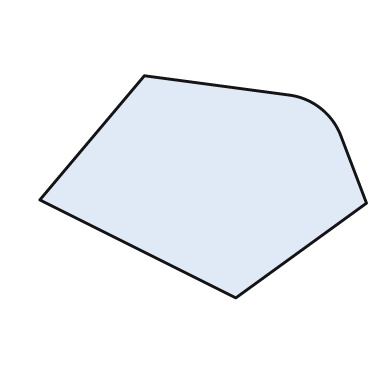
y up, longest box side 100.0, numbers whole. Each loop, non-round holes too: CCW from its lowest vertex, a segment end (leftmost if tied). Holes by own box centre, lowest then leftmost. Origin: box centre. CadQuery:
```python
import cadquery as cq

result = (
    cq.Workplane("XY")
    .moveTo(10.0, -34.0)
    .lineTo(50.0, -5.0)
    .lineTo(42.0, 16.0)
    .threePointArc((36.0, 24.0), (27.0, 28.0))
    .lineTo(-18.0, 34.0)
    .lineTo(-50.0, -4.0)
    .close()
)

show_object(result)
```